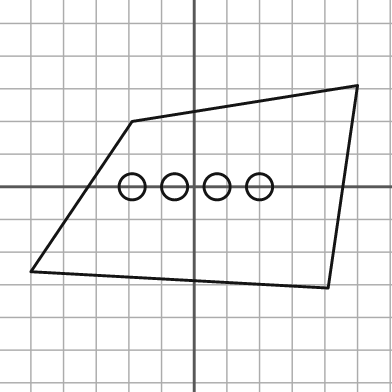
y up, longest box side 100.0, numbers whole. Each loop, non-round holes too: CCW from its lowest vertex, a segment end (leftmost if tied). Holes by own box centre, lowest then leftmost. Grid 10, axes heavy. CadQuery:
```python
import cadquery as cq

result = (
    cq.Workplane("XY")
    .moveTo(41.0, -31.0)
    .lineTo(50.0, 31.0)
    .lineTo(-19.0, 20.0)
    .lineTo(-50.0, -26.0)
    .close()
    .moveTo(-19.0, 0.0)
    .circle(4.0)
    .moveTo(-6.0, 0.0)
    .circle(4.0)
    .moveTo(7.0, 0.0)
    .circle(4.0)
    .moveTo(20.0, 0.0)
    .circle(4.0)
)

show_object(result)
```